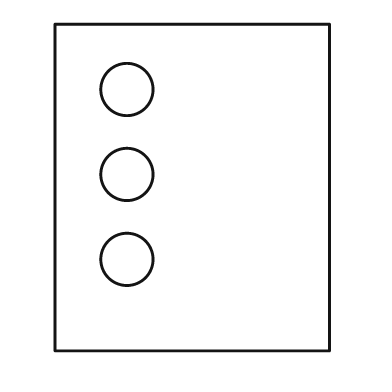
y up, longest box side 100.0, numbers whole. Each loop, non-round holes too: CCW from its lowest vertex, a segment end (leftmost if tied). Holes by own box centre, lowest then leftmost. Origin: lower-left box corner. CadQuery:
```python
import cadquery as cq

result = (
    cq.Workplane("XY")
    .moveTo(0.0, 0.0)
    .lineTo(84.0, 0.0)
    .lineTo(84.0, 100.0)
    .lineTo(0.0, 100.0)
    .close()
    .moveTo(22.0, 28.0)
    .circle(8.0)
    .moveTo(22.0, 54.0)
    .circle(8.0)
    .moveTo(22.0, 80.0)
    .circle(8.0)
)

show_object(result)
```